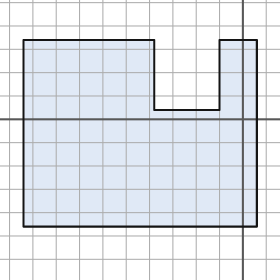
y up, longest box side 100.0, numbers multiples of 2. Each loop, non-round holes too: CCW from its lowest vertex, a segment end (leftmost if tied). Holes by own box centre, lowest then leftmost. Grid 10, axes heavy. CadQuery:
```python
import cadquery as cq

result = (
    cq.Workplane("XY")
    .moveTo(-94.0, -46.0)
    .lineTo(6.0, -46.0)
    .lineTo(6.0, 34.0)
    .lineTo(-10.0, 34.0)
    .lineTo(-10.0, 4.0)
    .lineTo(-38.0, 4.0)
    .lineTo(-38.0, 34.0)
    .lineTo(-94.0, 34.0)
    .close()
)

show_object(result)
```